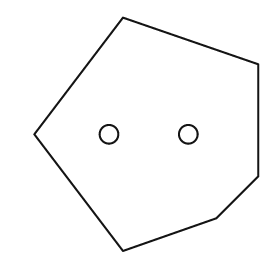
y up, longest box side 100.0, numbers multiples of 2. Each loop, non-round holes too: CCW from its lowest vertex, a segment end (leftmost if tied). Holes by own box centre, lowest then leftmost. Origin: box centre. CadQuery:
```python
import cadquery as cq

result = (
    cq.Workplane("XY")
    .moveTo(-10.0, -50.0)
    .lineTo(30.0, -36.0)
    .lineTo(48.0, -18.0)
    .lineTo(48.0, 30.0)
    .lineTo(-10.0, 50.0)
    .lineTo(-48.0, 0.0)
    .close()
    .moveTo(-16.0, 0.0)
    .circle(4.0)
    .moveTo(18.0, 0.0)
    .circle(4.0)
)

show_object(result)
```